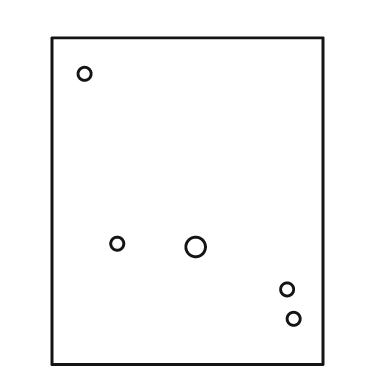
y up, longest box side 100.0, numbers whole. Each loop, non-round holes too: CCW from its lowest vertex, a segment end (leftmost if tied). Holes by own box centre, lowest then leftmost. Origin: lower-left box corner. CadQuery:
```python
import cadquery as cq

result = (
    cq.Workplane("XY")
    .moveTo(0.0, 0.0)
    .lineTo(83.0, 0.0)
    .lineTo(83.0, 100.0)
    .lineTo(0.0, 100.0)
    .close()
    .moveTo(74.0, 14.0)
    .circle(2.0)
    .moveTo(72.0, 23.0)
    .circle(2.0)
    .moveTo(44.0, 36.0)
    .circle(3.0)
    .moveTo(20.0, 37.0)
    .circle(2.0)
    .moveTo(10.0, 89.0)
    .circle(2.0)
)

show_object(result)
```